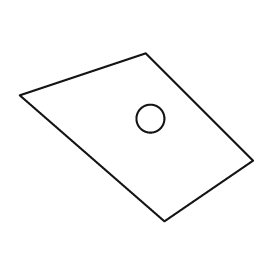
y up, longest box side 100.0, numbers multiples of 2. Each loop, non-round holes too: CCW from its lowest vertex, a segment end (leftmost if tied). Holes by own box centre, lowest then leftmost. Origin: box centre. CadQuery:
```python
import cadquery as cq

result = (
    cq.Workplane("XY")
    .moveTo(12.0, -36.0)
    .lineTo(50.0, -10.0)
    .lineTo(4.0, 36.0)
    .lineTo(-50.0, 18.0)
    .close()
    .moveTo(6.0, 8.0)
    .circle(6.0)
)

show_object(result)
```